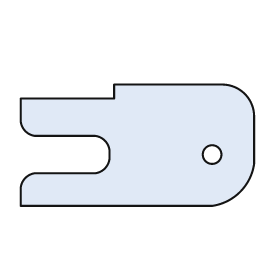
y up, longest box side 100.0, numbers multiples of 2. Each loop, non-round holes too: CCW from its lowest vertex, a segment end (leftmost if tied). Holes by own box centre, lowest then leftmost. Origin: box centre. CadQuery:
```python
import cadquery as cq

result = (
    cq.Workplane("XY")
    .moveTo(-50.0, -26.0)
    .lineTo(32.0, -26.0)
    .threePointArc((44.0, -20.0), (50.0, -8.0))
    .lineTo(50.0, 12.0)
    .threePointArc((46.0, 22.0), (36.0, 26.0))
    .lineTo(-10.0, 26.0)
    .lineTo(-10.0, 20.0)
    .lineTo(-50.0, 20.0)
    .lineTo(-50.0, 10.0)
    .threePointArc((-48.0, 6.0), (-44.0, 4.0))
    .lineTo(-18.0, 4.0)
    .threePointArc((-14.0, 2.0), (-12.0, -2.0))
    .lineTo(-12.0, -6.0)
    .threePointArc((-14.0, -10.0), (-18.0, -12.0))
    .lineTo(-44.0, -12.0)
    .threePointArc((-48.0, -14.0), (-50.0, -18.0))
    .close()
    .moveTo(32.0, -4.0)
    .circle(4.0)
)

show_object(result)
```